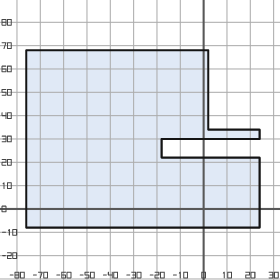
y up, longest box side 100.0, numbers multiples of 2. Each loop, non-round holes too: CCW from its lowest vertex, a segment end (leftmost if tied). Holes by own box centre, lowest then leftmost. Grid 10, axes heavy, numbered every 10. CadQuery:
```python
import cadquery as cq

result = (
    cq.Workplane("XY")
    .moveTo(-76.0, -8.0)
    .lineTo(24.0, -8.0)
    .lineTo(24.0, 22.0)
    .lineTo(-18.0, 22.0)
    .lineTo(-18.0, 30.0)
    .lineTo(24.0, 30.0)
    .lineTo(24.0, 34.0)
    .lineTo(2.0, 34.0)
    .lineTo(2.0, 68.0)
    .lineTo(-76.0, 68.0)
    .close()
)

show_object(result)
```